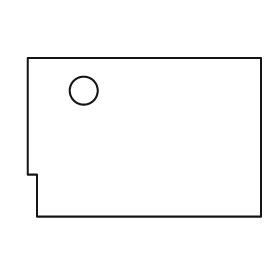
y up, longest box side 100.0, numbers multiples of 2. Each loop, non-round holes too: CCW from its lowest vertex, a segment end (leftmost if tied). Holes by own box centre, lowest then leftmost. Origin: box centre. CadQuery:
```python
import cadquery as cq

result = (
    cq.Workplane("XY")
    .moveTo(-46.0, -34.0)
    .lineTo(50.0, -34.0)
    .lineTo(50.0, 34.0)
    .lineTo(-50.0, 34.0)
    .lineTo(-50.0, -16.0)
    .lineTo(-46.0, -16.0)
    .close()
    .moveTo(-26.0, 20.0)
    .circle(6.0)
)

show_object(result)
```